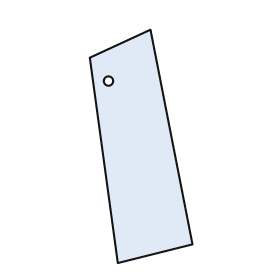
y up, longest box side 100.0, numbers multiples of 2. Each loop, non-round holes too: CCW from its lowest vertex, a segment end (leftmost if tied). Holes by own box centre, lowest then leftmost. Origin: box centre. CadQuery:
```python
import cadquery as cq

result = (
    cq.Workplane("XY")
    .moveTo(-10.0, -50.0)
    .lineTo(22.0, -42.0)
    .lineTo(4.0, 50.0)
    .lineTo(-22.0, 38.0)
    .close()
    .moveTo(-14.0, 28.0)
    .circle(2.0)
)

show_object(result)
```